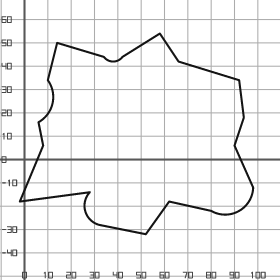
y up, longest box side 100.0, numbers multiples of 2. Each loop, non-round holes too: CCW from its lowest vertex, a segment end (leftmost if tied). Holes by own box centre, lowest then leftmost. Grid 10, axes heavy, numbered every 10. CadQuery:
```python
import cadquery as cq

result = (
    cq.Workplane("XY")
    .moveTo(52.0, -32.0)
    .lineTo(62.0, -18.0)
    .lineTo(80.0, -22.0)
    .threePointArc((92.0, -22.0), (98.0, -12.0))
    .lineTo(90.0, 6.0)
    .lineTo(94.0, 18.0)
    .lineTo(92.0, 34.0)
    .lineTo(66.0, 42.0)
    .lineTo(58.0, 54.0)
    .lineTo(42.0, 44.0)
    .threePointArc((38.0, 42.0), (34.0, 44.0))
    .lineTo(14.0, 50.0)
    .lineTo(10.0, 34.0)
    .threePointArc((12.0, 24.0), (6.0, 16.0))
    .lineTo(8.0, 6.0)
    .lineTo(-2.0, -18.0)
    .lineTo(28.0, -14.0)
    .threePointArc((26.0, -22.0), (32.0, -28.0))
    .close()
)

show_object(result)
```